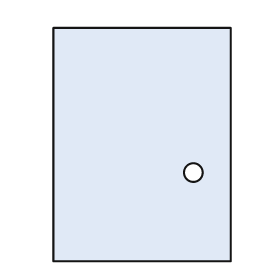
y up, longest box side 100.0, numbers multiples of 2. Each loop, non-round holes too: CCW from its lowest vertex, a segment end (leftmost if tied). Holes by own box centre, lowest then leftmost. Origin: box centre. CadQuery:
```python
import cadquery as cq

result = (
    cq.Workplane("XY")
    .moveTo(-38.0, -50.0)
    .lineTo(38.0, -50.0)
    .lineTo(38.0, 50.0)
    .lineTo(-38.0, 50.0)
    .close()
    .moveTo(22.0, -12.0)
    .circle(4.0)
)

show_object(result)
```